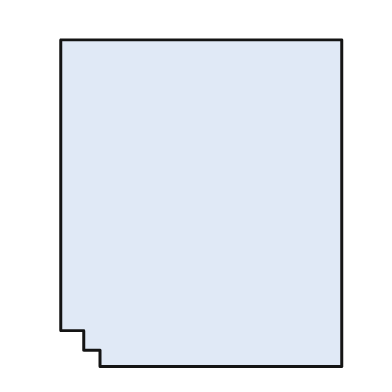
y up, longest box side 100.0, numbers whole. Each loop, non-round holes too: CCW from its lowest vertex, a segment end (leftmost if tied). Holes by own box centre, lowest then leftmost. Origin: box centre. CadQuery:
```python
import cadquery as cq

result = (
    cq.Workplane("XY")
    .moveTo(-31.0, -50.0)
    .lineTo(43.0, -50.0)
    .lineTo(43.0, 50.0)
    .lineTo(-43.0, 50.0)
    .lineTo(-43.0, -39.0)
    .lineTo(-36.0, -39.0)
    .lineTo(-36.0, -45.0)
    .lineTo(-31.0, -45.0)
    .close()
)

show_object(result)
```